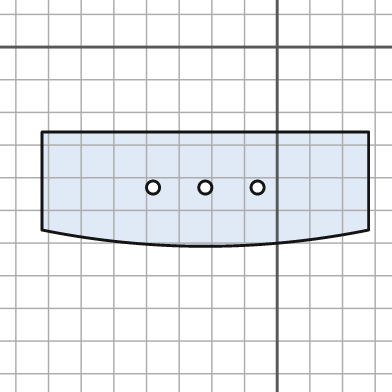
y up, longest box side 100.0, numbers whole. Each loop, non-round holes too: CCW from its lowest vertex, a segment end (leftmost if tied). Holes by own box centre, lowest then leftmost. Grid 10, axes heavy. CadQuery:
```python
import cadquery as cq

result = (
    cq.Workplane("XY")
    .moveTo(-72.0, -56.0)
    .threePointArc((-22.0, -61.0), (28.0, -56.0))
    .lineTo(28.0, -26.0)
    .lineTo(-72.0, -26.0)
    .close()
    .moveTo(-38.0, -43.0)
    .circle(2.0)
    .moveTo(-22.0, -43.0)
    .circle(2.0)
    .moveTo(-6.0, -43.0)
    .circle(2.0)
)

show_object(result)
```